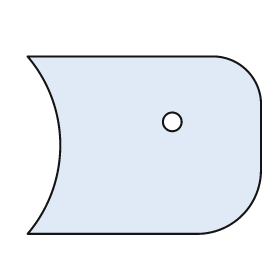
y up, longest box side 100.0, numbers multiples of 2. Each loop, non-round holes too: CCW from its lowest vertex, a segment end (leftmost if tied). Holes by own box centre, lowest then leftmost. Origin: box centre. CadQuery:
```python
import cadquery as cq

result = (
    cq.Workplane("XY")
    .moveTo(-50.0, -38.0)
    .lineTo(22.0, -38.0)
    .threePointArc((42.0, -30.0), (50.0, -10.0))
    .lineTo(50.0, 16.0)
    .threePointArc((44.0, 32.0), (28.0, 38.0))
    .lineTo(-50.0, 38.0)
    .threePointArc((-36.0, 0.0), (-50.0, -38.0))
    .close()
    .moveTo(12.0, 10.0)
    .circle(4.0)
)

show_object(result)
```